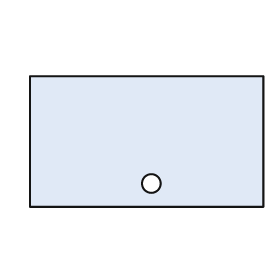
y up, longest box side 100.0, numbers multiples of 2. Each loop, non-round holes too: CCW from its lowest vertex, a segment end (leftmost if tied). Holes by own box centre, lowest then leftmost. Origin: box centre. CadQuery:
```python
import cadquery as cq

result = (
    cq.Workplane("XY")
    .moveTo(-50.0, -28.0)
    .lineTo(50.0, -28.0)
    .lineTo(50.0, 28.0)
    .lineTo(-50.0, 28.0)
    .close()
    .moveTo(2.0, -18.0)
    .circle(4.0)
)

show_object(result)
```